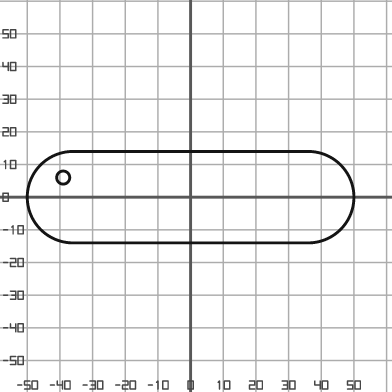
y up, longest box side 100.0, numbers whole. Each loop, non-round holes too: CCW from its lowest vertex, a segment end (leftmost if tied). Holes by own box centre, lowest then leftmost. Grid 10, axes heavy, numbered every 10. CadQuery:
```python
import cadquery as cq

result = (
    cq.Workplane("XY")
    .moveTo(-36.0, -14.0)
    .lineTo(36.0, -14.0)
    .threePointArc((50.0, 0.0), (36.0, 14.0))
    .lineTo(-36.0, 14.0)
    .threePointArc((-50.0, 0.0), (-36.0, -14.0))
    .close()
    .moveTo(-39.0, 6.0)
    .circle(2.0)
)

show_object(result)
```